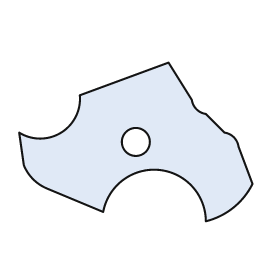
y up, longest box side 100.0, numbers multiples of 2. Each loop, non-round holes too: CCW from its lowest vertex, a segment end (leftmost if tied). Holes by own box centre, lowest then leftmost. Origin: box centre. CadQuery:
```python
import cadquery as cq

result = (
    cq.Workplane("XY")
    .moveTo(30.0, -34.0)
    .threePointArc((42.0, -28.0), (50.0, -18.0))
    .lineTo(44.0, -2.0)
    .threePointArc((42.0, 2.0), (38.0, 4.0))
    .lineTo(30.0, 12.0)
    .threePointArc((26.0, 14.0), (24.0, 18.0))
    .lineTo(14.0, 34.0)
    .lineTo(-24.0, 20.0)
    .threePointArc((-32.0, 4.0), (-50.0, 4.0))
    .lineTo(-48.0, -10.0)
    .threePointArc((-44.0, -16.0), (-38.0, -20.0))
    .lineTo(-14.0, -30.0)
    .threePointArc((10.0, -12.0), (30.0, -34.0))
    .close()
    .moveTo(0.0, 0.0)
    .circle(6.0)
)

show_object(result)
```